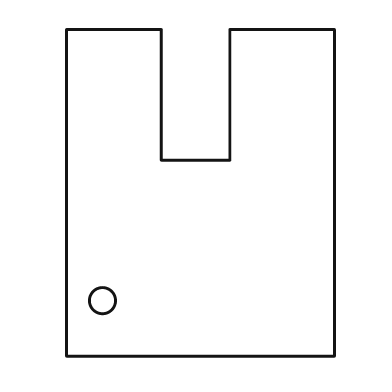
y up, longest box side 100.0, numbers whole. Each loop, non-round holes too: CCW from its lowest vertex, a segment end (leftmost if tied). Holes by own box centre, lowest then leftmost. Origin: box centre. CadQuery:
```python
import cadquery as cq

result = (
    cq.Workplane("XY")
    .moveTo(-41.0, -50.0)
    .lineTo(41.0, -50.0)
    .lineTo(41.0, 50.0)
    .lineTo(9.0, 50.0)
    .lineTo(9.0, 10.0)
    .lineTo(-12.0, 10.0)
    .lineTo(-12.0, 50.0)
    .lineTo(-41.0, 50.0)
    .close()
    .moveTo(-30.0, -33.0)
    .circle(4.0)
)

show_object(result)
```